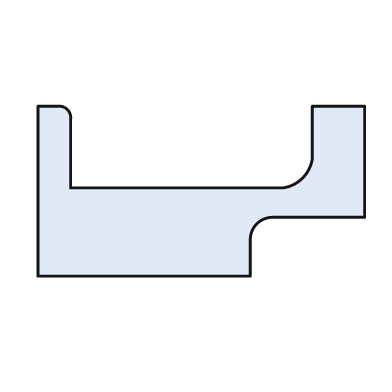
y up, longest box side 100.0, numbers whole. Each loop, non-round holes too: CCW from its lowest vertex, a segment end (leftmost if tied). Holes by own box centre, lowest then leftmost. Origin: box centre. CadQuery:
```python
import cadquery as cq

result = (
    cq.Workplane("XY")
    .moveTo(-50.0, -26.0)
    .lineTo(15.0, -26.0)
    .lineTo(15.0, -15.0)
    .threePointArc((17.0, -10.0), (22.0, -8.0))
    .lineTo(50.0, -8.0)
    .lineTo(50.0, 26.0)
    .lineTo(34.0, 26.0)
    .lineTo(34.0, 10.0)
    .threePointArc((31.0, 4.0), (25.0, 1.0))
    .lineTo(-40.0, 1.0)
    .lineTo(-40.0, 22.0)
    .threePointArc((-41.0, 25.0), (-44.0, 26.0))
    .lineTo(-50.0, 26.0)
    .close()
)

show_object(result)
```